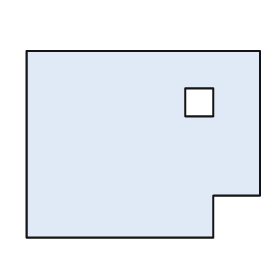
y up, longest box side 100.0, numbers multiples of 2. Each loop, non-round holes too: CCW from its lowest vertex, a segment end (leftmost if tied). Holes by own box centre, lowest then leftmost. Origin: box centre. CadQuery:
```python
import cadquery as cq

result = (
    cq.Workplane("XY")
    .moveTo(-50.0, -40.0)
    .lineTo(30.0, -40.0)
    .lineTo(30.0, -22.0)
    .lineTo(50.0, -22.0)
    .lineTo(50.0, 40.0)
    .lineTo(-50.0, 40.0)
    .close()
    .moveTo(18.0, 12.0)
    .lineTo(30.0, 12.0)
    .lineTo(30.0, 24.0)
    .lineTo(18.0, 24.0)
    .close()
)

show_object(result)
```